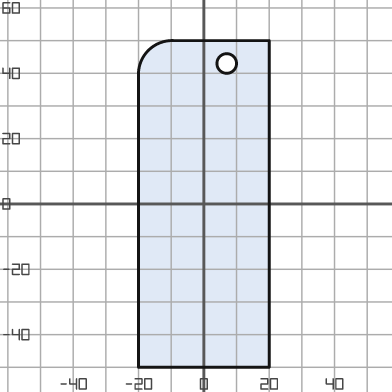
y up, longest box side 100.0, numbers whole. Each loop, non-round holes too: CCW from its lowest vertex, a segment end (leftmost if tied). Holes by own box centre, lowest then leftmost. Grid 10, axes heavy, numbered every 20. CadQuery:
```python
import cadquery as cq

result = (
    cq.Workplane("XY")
    .moveTo(-20.0, -50.0)
    .lineTo(20.0, -50.0)
    .lineTo(20.0, 50.0)
    .lineTo(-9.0, 50.0)
    .threePointArc((-17.0, 47.0), (-20.0, 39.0))
    .close()
    .moveTo(7.0, 43.0)
    .circle(3.0)
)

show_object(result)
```